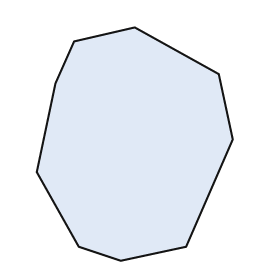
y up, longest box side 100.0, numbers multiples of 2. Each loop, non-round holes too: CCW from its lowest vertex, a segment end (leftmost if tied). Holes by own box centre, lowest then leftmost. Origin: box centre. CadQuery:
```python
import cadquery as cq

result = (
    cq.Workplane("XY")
    .moveTo(-6.0, -50.0)
    .lineTo(22.0, -44.0)
    .lineTo(42.0, 2.0)
    .lineTo(36.0, 30.0)
    .lineTo(0.0, 50.0)
    .lineTo(-26.0, 44.0)
    .lineTo(-34.0, 26.0)
    .lineTo(-42.0, -12.0)
    .lineTo(-24.0, -44.0)
    .close()
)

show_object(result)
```